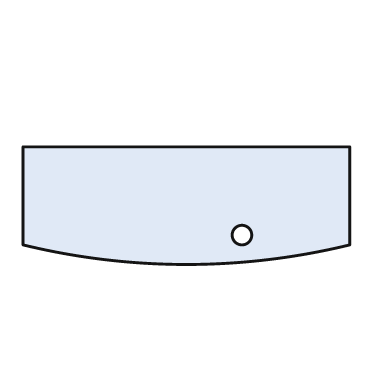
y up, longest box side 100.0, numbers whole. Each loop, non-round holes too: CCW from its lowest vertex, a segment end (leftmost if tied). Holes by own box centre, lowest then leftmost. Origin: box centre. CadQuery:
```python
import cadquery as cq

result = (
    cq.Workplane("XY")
    .moveTo(-50.0, -12.0)
    .threePointArc((0.0, -18.0), (50.0, -12.0))
    .lineTo(50.0, 18.0)
    .lineTo(-50.0, 18.0)
    .close()
    .moveTo(17.0, -9.0)
    .circle(3.0)
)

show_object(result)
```